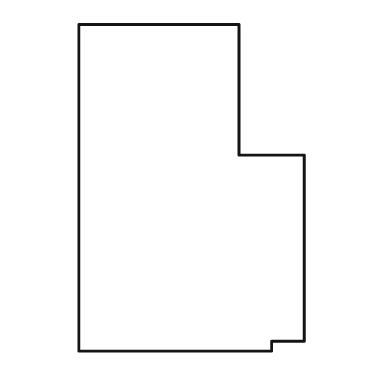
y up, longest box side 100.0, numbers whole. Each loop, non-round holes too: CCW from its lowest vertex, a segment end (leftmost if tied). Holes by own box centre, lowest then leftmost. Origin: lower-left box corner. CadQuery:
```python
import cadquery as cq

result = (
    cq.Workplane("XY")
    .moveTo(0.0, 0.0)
    .lineTo(59.0, 0.0)
    .lineTo(59.0, 3.0)
    .lineTo(69.0, 3.0)
    .lineTo(69.0, 60.0)
    .lineTo(49.0, 60.0)
    .lineTo(49.0, 100.0)
    .lineTo(0.0, 100.0)
    .close()
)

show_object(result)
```